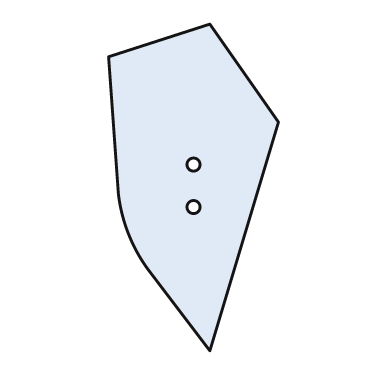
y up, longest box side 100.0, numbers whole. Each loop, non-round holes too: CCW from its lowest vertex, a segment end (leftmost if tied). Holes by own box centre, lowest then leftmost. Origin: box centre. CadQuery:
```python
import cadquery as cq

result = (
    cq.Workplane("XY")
    .moveTo(5.0, -50.0)
    .lineTo(26.0, 20.0)
    .lineTo(5.0, 50.0)
    .lineTo(-26.0, 40.0)
    .lineTo(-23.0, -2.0)
    .threePointArc((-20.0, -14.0), (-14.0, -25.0))
    .close()
    .moveTo(0.0, -6.0)
    .circle(2.0)
    .moveTo(0.0, 7.0)
    .circle(2.0)
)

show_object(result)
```